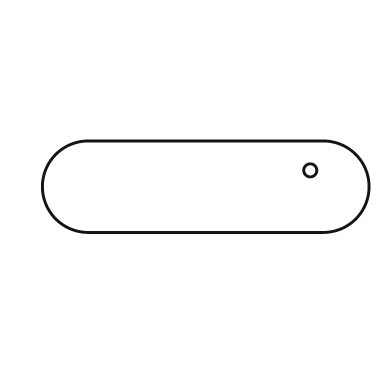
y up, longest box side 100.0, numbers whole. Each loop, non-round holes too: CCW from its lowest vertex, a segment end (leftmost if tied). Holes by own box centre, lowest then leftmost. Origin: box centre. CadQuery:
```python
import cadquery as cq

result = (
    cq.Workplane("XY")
    .moveTo(-36.0, -14.0)
    .lineTo(36.0, -14.0)
    .threePointArc((50.0, 0.0), (36.0, 14.0))
    .lineTo(-36.0, 14.0)
    .threePointArc((-50.0, 0.0), (-36.0, -14.0))
    .close()
    .moveTo(32.0, 5.0)
    .circle(2.0)
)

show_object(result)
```